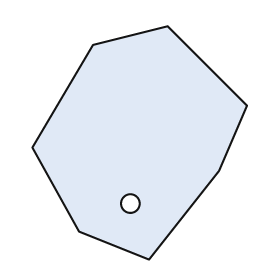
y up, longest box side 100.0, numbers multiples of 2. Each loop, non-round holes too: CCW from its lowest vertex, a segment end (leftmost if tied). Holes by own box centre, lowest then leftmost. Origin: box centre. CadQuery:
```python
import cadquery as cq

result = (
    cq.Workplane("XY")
    .moveTo(4.0, -50.0)
    .lineTo(34.0, -12.0)
    .lineTo(46.0, 16.0)
    .lineTo(12.0, 50.0)
    .lineTo(-20.0, 42.0)
    .lineTo(-46.0, -2.0)
    .lineTo(-26.0, -38.0)
    .close()
    .moveTo(-4.0, -26.0)
    .circle(4.0)
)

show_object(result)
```